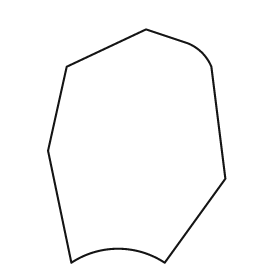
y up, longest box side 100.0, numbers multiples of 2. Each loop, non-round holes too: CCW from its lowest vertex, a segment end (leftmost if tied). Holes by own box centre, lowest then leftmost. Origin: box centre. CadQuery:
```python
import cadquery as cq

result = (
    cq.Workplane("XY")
    .moveTo(-28.0, -50.0)
    .threePointArc((-8.0, -44.0), (12.0, -50.0))
    .lineTo(38.0, -14.0)
    .lineTo(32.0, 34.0)
    .threePointArc((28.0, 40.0), (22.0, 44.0))
    .lineTo(4.0, 50.0)
    .lineTo(-30.0, 34.0)
    .lineTo(-38.0, -2.0)
    .close()
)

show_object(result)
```